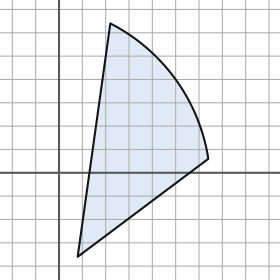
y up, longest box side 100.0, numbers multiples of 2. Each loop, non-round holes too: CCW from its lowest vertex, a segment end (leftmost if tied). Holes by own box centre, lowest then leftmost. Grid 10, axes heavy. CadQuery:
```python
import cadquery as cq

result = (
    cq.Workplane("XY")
    .moveTo(8.0, -36.0)
    .lineTo(64.0, 6.0)
    .threePointArc((50.0, 40.0), (22.0, 64.0))
    .close()
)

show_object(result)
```